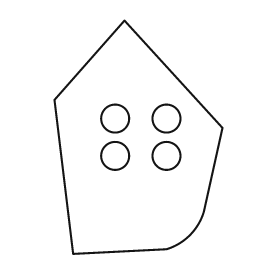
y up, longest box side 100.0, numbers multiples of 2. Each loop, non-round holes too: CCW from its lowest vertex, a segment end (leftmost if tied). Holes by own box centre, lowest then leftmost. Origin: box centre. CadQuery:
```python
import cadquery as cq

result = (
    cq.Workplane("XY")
    .moveTo(-28.0, -50.0)
    .lineTo(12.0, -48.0)
    .threePointArc((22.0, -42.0), (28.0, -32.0))
    .lineTo(36.0, 4.0)
    .lineTo(-6.0, 50.0)
    .lineTo(-36.0, 16.0)
    .close()
    .moveTo(-10.0, -8.0)
    .circle(6.0)
    .moveTo(12.0, -8.0)
    .circle(6.0)
    .moveTo(-10.0, 8.0)
    .circle(6.0)
    .moveTo(12.0, 8.0)
    .circle(6.0)
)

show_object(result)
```